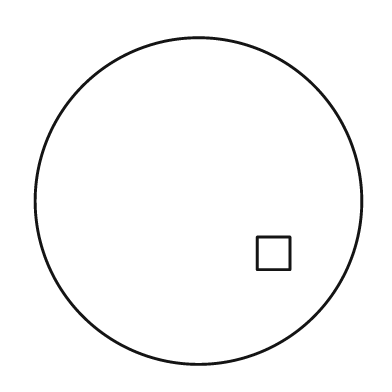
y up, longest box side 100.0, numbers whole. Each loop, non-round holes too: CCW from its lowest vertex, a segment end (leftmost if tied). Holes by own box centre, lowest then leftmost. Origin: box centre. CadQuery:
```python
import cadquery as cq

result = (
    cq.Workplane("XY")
    .moveTo(0.0, 0.0)
    .circle(50.0)
    .moveTo(18.0, -21.0)
    .lineTo(28.0, -21.0)
    .lineTo(28.0, -11.0)
    .lineTo(18.0, -11.0)
    .close()
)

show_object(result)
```